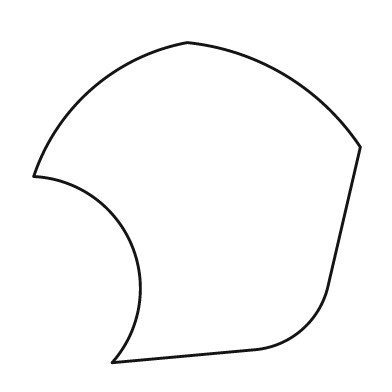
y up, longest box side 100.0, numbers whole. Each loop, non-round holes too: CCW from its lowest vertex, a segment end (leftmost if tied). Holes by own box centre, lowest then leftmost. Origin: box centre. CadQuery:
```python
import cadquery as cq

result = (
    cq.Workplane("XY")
    .moveTo(-26.0, -49.0)
    .lineTo(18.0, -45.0)
    .threePointArc((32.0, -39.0), (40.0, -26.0))
    .lineTo(50.0, 17.0)
    .threePointArc((27.0, 39.0), (-3.0, 49.0))
    .threePointArc((-32.0, 35.0), (-50.0, 8.0))
    .threePointArc((-20.0, -13.0), (-26.0, -49.0))
    .close()
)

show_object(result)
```